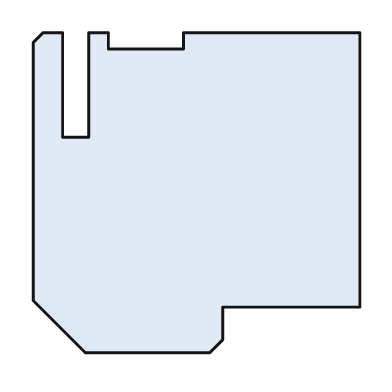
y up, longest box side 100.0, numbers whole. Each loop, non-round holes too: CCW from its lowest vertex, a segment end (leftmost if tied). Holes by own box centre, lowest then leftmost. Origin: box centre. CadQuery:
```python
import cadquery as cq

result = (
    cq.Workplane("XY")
    .moveTo(-34.0, -49.0)
    .lineTo(4.0, -49.0)
    .lineTo(8.0, -45.0)
    .lineTo(8.0, -35.0)
    .lineTo(50.0, -35.0)
    .lineTo(50.0, 49.0)
    .lineTo(-4.0, 49.0)
    .lineTo(-4.0, 44.0)
    .lineTo(-27.0, 44.0)
    .lineTo(-27.0, 49.0)
    .lineTo(-33.0, 49.0)
    .lineTo(-33.0, 17.0)
    .lineTo(-41.0, 17.0)
    .lineTo(-41.0, 49.0)
    .lineTo(-47.0, 49.0)
    .lineTo(-50.0, 46.0)
    .lineTo(-50.0, -33.0)
    .close()
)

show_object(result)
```